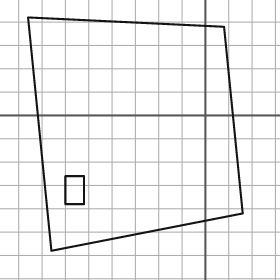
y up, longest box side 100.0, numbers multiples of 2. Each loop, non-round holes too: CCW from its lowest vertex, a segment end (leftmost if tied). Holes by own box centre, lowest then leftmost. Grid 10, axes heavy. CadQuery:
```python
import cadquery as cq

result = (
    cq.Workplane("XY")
    .moveTo(-66.0, -58.0)
    .lineTo(16.0, -42.0)
    .lineTo(8.0, 38.0)
    .lineTo(-76.0, 42.0)
    .close()
    .moveTo(-60.0, -38.0)
    .lineTo(-52.0, -38.0)
    .lineTo(-52.0, -26.0)
    .lineTo(-60.0, -26.0)
    .close()
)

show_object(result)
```